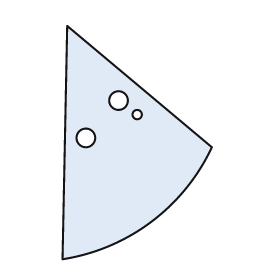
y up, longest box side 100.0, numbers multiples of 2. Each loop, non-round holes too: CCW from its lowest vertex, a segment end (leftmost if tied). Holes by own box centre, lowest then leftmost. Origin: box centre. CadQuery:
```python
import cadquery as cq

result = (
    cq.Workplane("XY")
    .moveTo(-32.0, -50.0)
    .threePointArc((6.0, -34.0), (32.0, -2.0))
    .lineTo(-30.0, 50.0)
    .close()
    .moveTo(-22.0, 2.0)
    .circle(4.0)
    .moveTo(0.0, 12.0)
    .circle(2.0)
    .moveTo(-8.0, 18.0)
    .circle(4.0)
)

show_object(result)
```